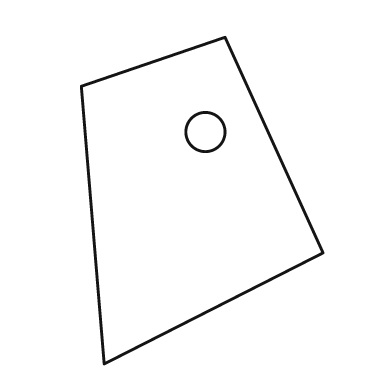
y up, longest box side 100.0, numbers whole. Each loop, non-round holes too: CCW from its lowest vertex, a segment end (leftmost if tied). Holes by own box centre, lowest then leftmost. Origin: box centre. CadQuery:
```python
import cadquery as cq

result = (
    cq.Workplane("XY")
    .moveTo(-30.0, -50.0)
    .lineTo(37.0, -16.0)
    .lineTo(7.0, 50.0)
    .lineTo(-37.0, 35.0)
    .close()
    .moveTo(1.0, 21.0)
    .circle(6.0)
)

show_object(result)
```